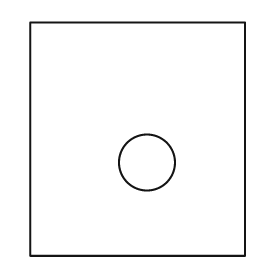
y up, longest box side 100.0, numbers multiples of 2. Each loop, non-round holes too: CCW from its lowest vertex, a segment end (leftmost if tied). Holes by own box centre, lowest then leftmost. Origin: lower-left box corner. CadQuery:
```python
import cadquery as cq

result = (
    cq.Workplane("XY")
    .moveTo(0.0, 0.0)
    .lineTo(92.0, 0.0)
    .lineTo(92.0, 100.0)
    .lineTo(0.0, 100.0)
    .close()
    .moveTo(50.0, 40.0)
    .circle(12.0)
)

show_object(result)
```